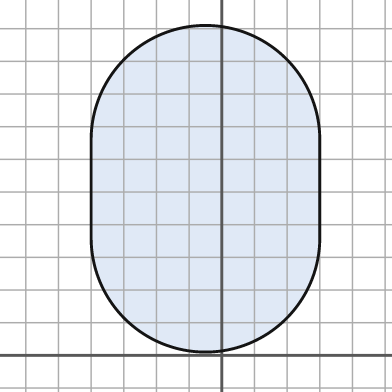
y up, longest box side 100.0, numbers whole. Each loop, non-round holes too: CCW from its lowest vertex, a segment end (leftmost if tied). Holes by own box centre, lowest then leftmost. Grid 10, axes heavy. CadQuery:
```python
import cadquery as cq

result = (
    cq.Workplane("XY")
    .moveTo(-40.0, 36.0)
    .threePointArc((-5.0, 1.0), (30.0, 36.0))
    .lineTo(30.0, 66.0)
    .threePointArc((-5.0, 101.0), (-40.0, 66.0))
    .close()
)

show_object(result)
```